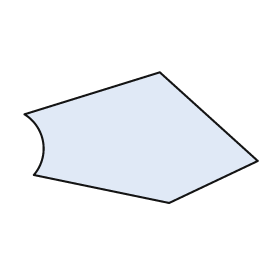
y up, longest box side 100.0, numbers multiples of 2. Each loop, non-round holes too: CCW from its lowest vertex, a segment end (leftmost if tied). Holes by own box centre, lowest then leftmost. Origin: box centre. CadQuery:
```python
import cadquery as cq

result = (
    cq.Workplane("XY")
    .moveTo(12.0, -28.0)
    .lineTo(50.0, -10.0)
    .lineTo(8.0, 28.0)
    .lineTo(-50.0, 10.0)
    .threePointArc((-42.0, -2.0), (-46.0, -16.0))
    .close()
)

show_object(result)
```